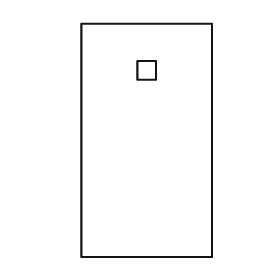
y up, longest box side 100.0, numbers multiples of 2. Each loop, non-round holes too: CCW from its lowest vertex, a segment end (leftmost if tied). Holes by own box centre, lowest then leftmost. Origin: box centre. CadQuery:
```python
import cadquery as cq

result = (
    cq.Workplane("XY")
    .moveTo(-28.0, -50.0)
    .lineTo(28.0, -50.0)
    .lineTo(28.0, 50.0)
    .lineTo(-28.0, 50.0)
    .close()
    .moveTo(-4.0, 26.0)
    .lineTo(4.0, 26.0)
    .lineTo(4.0, 34.0)
    .lineTo(-4.0, 34.0)
    .close()
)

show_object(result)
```